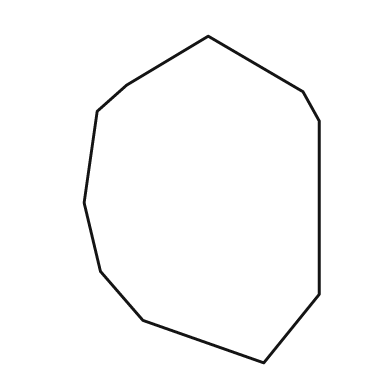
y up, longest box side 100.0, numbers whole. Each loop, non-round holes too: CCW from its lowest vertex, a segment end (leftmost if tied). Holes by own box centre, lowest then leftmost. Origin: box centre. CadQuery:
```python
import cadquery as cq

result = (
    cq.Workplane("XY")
    .moveTo(19.0, -50.0)
    .lineTo(36.0, -29.0)
    .lineTo(36.0, 24.0)
    .lineTo(31.0, 33.0)
    .lineTo(2.0, 50.0)
    .lineTo(-23.0, 35.0)
    .lineTo(-32.0, 27.0)
    .lineTo(-36.0, -1.0)
    .lineTo(-31.0, -22.0)
    .lineTo(-18.0, -37.0)
    .close()
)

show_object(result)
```